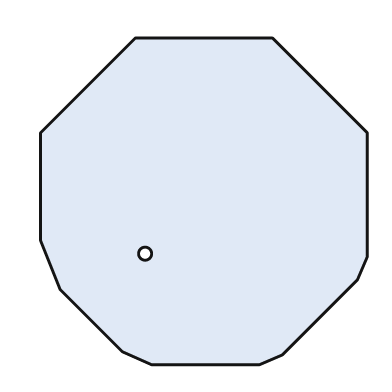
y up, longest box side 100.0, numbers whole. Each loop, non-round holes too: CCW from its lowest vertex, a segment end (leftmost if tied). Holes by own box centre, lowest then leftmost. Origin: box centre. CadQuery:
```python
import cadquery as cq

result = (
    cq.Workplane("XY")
    .moveTo(-16.0, -50.0)
    .lineTo(17.0, -50.0)
    .lineTo(24.0, -47.0)
    .lineTo(47.0, -24.0)
    .lineTo(50.0, -17.0)
    .lineTo(50.0, 21.0)
    .lineTo(21.0, 50.0)
    .lineTo(-21.0, 50.0)
    .lineTo(-50.0, 21.0)
    .lineTo(-50.0, -12.0)
    .lineTo(-44.0, -27.0)
    .lineTo(-25.0, -46.0)
    .close()
    .moveTo(-18.0, -16.0)
    .circle(2.0)
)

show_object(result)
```